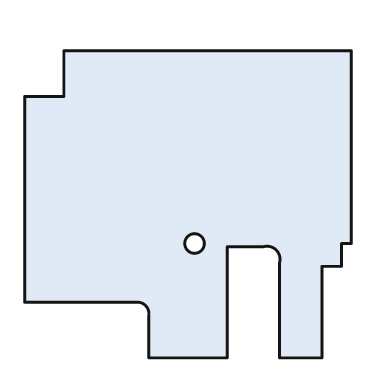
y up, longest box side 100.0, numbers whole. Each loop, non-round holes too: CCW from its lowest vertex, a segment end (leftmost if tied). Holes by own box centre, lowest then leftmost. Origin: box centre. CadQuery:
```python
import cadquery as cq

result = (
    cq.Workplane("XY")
    .moveTo(-12.0, -47.0)
    .lineTo(12.0, -47.0)
    .lineTo(12.0, -13.0)
    .lineTo(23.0, -13.0)
    .threePointArc((27.0, -14.0), (28.0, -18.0))
    .lineTo(28.0, -47.0)
    .lineTo(41.0, -47.0)
    .lineTo(41.0, -19.0)
    .lineTo(47.0, -19.0)
    .lineTo(47.0, -12.0)
    .lineTo(50.0, -12.0)
    .lineTo(50.0, 47.0)
    .lineTo(-38.0, 47.0)
    .lineTo(-38.0, 33.0)
    .lineTo(-50.0, 33.0)
    .lineTo(-50.0, -30.0)
    .lineTo(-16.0, -30.0)
    .threePointArc((-13.0, -31.0), (-12.0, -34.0))
    .close()
    .moveTo(2.0, -12.0)
    .circle(3.0)
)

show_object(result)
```